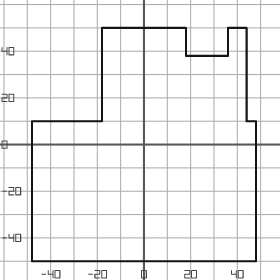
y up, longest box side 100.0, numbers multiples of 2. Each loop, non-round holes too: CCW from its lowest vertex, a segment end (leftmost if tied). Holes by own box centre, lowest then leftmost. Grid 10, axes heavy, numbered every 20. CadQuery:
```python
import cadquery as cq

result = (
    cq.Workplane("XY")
    .moveTo(-48.0, -50.0)
    .lineTo(48.0, -50.0)
    .lineTo(48.0, 10.0)
    .lineTo(44.0, 10.0)
    .lineTo(44.0, 50.0)
    .lineTo(36.0, 50.0)
    .lineTo(36.0, 38.0)
    .lineTo(18.0, 38.0)
    .lineTo(18.0, 50.0)
    .lineTo(-18.0, 50.0)
    .lineTo(-18.0, 10.0)
    .lineTo(-48.0, 10.0)
    .close()
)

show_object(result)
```